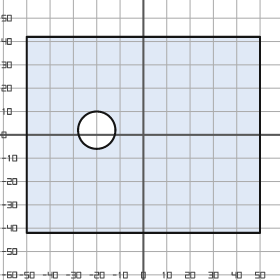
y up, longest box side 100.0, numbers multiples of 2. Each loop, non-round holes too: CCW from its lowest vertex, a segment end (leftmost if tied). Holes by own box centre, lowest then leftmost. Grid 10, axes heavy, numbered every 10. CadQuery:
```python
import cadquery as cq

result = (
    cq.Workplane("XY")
    .moveTo(-50.0, -42.0)
    .lineTo(50.0, -42.0)
    .lineTo(50.0, 42.0)
    .lineTo(-50.0, 42.0)
    .close()
    .moveTo(-20.0, 2.0)
    .circle(8.0)
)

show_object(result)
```